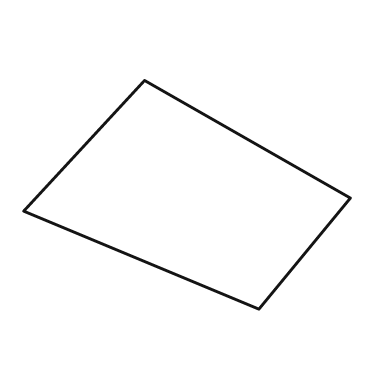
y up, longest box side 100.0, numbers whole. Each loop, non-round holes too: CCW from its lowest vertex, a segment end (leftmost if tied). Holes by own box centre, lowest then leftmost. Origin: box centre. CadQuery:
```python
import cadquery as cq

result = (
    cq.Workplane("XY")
    .moveTo(22.0, -35.0)
    .lineTo(50.0, -1.0)
    .lineTo(-13.0, 35.0)
    .lineTo(-50.0, -5.0)
    .close()
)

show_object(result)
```